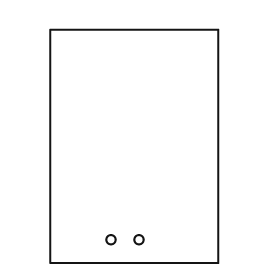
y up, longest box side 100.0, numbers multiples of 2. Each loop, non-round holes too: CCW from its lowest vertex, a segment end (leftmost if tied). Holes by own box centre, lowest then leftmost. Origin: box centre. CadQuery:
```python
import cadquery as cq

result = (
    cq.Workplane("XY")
    .moveTo(-36.0, -50.0)
    .lineTo(36.0, -50.0)
    .lineTo(36.0, 50.0)
    .lineTo(-36.0, 50.0)
    .close()
    .moveTo(-10.0, -40.0)
    .circle(2.0)
    .moveTo(2.0, -40.0)
    .circle(2.0)
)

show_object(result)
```